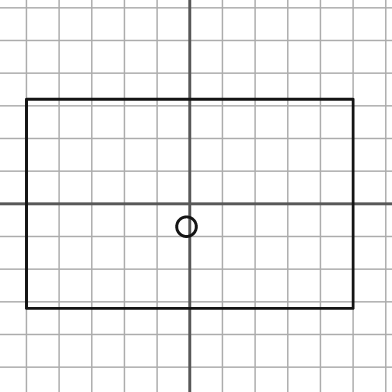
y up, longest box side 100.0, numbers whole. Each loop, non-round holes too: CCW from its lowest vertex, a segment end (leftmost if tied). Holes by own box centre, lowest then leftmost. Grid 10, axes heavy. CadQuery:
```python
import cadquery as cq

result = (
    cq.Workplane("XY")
    .moveTo(-50.0, -32.0)
    .lineTo(50.0, -32.0)
    .lineTo(50.0, 32.0)
    .lineTo(-50.0, 32.0)
    .close()
    .moveTo(-1.0, -7.0)
    .circle(3.0)
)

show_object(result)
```